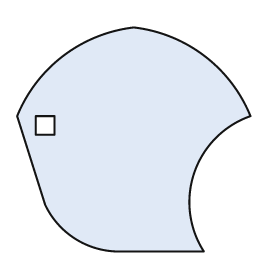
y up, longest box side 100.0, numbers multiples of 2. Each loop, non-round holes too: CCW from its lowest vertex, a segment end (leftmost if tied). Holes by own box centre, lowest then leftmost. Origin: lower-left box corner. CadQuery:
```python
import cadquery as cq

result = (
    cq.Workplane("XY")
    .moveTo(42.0, 0.0)
    .lineTo(80.0, 0.0)
    .threePointArc((76.0, 34.0), (100.0, 58.0))
    .threePointArc((80.0, 84.0), (50.0, 96.0))
    .threePointArc((20.0, 84.0), (0.0, 58.0))
    .lineTo(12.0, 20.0)
    .threePointArc((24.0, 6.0), (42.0, 0.0))
    .close()
    .moveTo(8.0, 50.0)
    .lineTo(16.0, 50.0)
    .lineTo(16.0, 58.0)
    .lineTo(8.0, 58.0)
    .close()
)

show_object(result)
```